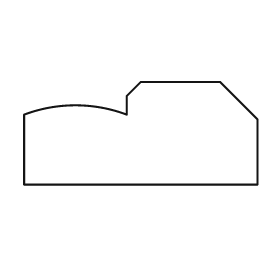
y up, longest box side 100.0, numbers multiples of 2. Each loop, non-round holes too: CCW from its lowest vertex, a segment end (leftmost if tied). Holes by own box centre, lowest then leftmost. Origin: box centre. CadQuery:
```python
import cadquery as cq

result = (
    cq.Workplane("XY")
    .moveTo(-50.0, -22.0)
    .lineTo(50.0, -22.0)
    .lineTo(50.0, 6.0)
    .lineTo(34.0, 22.0)
    .lineTo(0.0, 22.0)
    .lineTo(-6.0, 16.0)
    .lineTo(-6.0, 8.0)
    .threePointArc((-28.0, 12.0), (-50.0, 8.0))
    .close()
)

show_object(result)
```